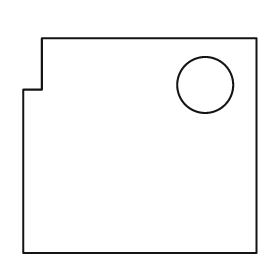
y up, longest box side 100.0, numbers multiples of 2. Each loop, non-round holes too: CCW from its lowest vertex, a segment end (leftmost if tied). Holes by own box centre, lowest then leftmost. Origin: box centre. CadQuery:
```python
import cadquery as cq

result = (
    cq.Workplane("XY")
    .moveTo(-50.0, -46.0)
    .lineTo(50.0, -46.0)
    .lineTo(50.0, 46.0)
    .lineTo(-42.0, 46.0)
    .lineTo(-42.0, 24.0)
    .lineTo(-50.0, 24.0)
    .close()
    .moveTo(28.0, 26.0)
    .circle(12.0)
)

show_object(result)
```